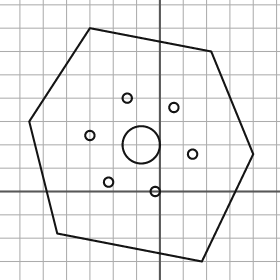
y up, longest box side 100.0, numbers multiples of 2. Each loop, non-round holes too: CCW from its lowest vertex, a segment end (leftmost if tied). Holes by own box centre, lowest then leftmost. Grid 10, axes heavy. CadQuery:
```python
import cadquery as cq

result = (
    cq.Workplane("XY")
    .moveTo(18.0, -30.0)
    .lineTo(40.0, 16.0)
    .lineTo(22.0, 60.0)
    .lineTo(-30.0, 70.0)
    .lineTo(-56.0, 30.0)
    .lineTo(-44.0, -18.0)
    .close()
    .moveTo(-2.0, 0.0)
    .circle(2.0)
    .moveTo(-22.0, 4.0)
    .circle(2.0)
    .moveTo(14.0, 16.0)
    .circle(2.0)
    .moveTo(-8.0, 20.0)
    .circle(8.0)
    .moveTo(-30.0, 24.0)
    .circle(2.0)
    .moveTo(6.0, 36.0)
    .circle(2.0)
    .moveTo(-14.0, 40.0)
    .circle(2.0)
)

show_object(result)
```